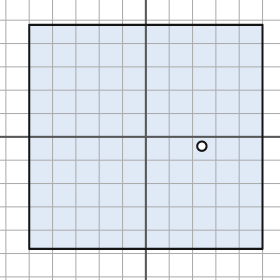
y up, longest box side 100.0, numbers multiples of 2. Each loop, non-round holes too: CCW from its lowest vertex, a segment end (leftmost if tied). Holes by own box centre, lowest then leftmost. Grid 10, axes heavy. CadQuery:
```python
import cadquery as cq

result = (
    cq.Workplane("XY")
    .moveTo(-50.0, -48.0)
    .lineTo(50.0, -48.0)
    .lineTo(50.0, 48.0)
    .lineTo(-50.0, 48.0)
    .close()
    .moveTo(24.0, -4.0)
    .circle(2.0)
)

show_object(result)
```